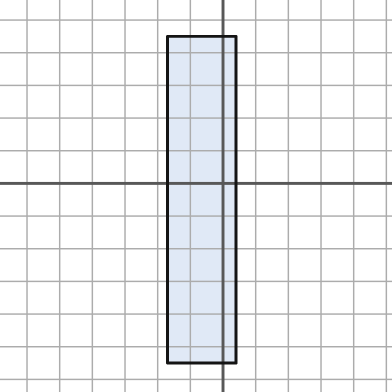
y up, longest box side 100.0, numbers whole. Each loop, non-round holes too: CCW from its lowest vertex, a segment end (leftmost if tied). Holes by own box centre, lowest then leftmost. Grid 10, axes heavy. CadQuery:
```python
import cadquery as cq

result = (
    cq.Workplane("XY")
    .moveTo(-17.0, -55.0)
    .lineTo(4.0, -55.0)
    .lineTo(4.0, 45.0)
    .lineTo(-17.0, 45.0)
    .close()
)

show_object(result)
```